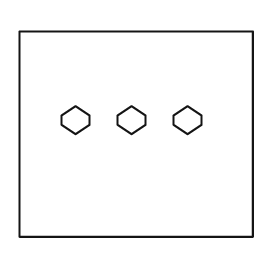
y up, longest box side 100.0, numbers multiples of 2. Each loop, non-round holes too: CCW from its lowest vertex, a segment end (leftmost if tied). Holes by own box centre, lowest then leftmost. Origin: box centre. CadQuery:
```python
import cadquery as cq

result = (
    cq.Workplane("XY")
    .moveTo(-50.0, -44.0)
    .lineTo(50.0, -44.0)
    .lineTo(50.0, 44.0)
    .lineTo(-50.0, 44.0)
    .close()
    .moveTo(-26.0, 0.0)
    .lineTo(-20.0, 4.0)
    .lineTo(-20.0, 8.0)
    .lineTo(-26.0, 12.0)
    .lineTo(-32.0, 8.0)
    .lineTo(-32.0, 4.0)
    .close()
    .moveTo(-2.0, 0.0)
    .lineTo(4.0, 4.0)
    .lineTo(4.0, 8.0)
    .lineTo(-2.0, 12.0)
    .lineTo(-8.0, 8.0)
    .lineTo(-8.0, 4.0)
    .close()
    .moveTo(22.0, 0.0)
    .lineTo(28.0, 4.0)
    .lineTo(28.0, 8.0)
    .lineTo(22.0, 12.0)
    .lineTo(16.0, 8.0)
    .lineTo(16.0, 4.0)
    .close()
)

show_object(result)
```